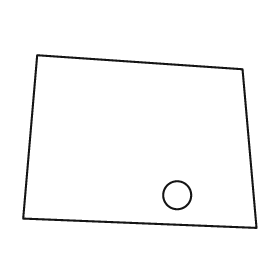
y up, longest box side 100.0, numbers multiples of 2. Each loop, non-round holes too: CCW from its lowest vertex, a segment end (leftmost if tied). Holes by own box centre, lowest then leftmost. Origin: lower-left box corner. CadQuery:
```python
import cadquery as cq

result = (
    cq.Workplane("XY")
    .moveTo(100.0, 0.0)
    .lineTo(94.0, 68.0)
    .lineTo(6.0, 74.0)
    .lineTo(0.0, 4.0)
    .close()
    .moveTo(66.0, 14.0)
    .circle(6.0)
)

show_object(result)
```